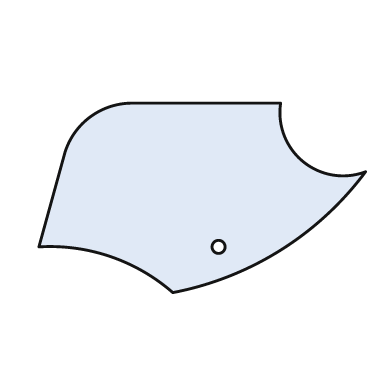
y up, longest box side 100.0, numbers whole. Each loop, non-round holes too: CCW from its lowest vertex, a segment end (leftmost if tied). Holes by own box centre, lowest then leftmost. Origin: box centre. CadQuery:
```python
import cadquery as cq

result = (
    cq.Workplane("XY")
    .moveTo(-9.0, -29.0)
    .threePointArc((24.0, -16.0), (50.0, 8.0))
    .threePointArc((31.0, 11.0), (24.0, 29.0))
    .lineTo(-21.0, 29.0)
    .threePointArc((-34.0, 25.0), (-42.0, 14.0))
    .lineTo(-50.0, -15.0)
    .threePointArc((-28.0, -18.0), (-9.0, -29.0))
    .close()
    .moveTo(5.0, -15.0)
    .circle(2.0)
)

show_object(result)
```